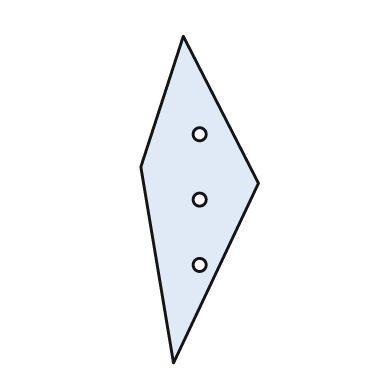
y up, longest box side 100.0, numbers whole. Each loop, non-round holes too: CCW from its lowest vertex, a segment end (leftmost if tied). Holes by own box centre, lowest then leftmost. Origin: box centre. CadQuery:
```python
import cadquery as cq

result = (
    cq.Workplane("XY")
    .moveTo(-8.0, -50.0)
    .lineTo(18.0, 5.0)
    .lineTo(-5.0, 50.0)
    .lineTo(-18.0, 10.0)
    .close()
    .moveTo(0.0, -20.0)
    .circle(2.0)
    .moveTo(0.0, 0.0)
    .circle(2.0)
    .moveTo(0.0, 20.0)
    .circle(2.0)
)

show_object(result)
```